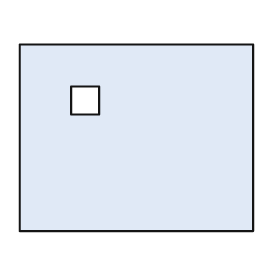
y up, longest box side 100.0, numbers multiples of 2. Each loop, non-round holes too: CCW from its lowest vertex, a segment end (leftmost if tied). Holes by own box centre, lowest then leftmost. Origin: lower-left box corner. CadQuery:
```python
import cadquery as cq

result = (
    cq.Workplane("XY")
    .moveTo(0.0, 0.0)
    .lineTo(100.0, 0.0)
    .lineTo(100.0, 80.0)
    .lineTo(0.0, 80.0)
    .close()
    .moveTo(22.0, 50.0)
    .lineTo(34.0, 50.0)
    .lineTo(34.0, 62.0)
    .lineTo(22.0, 62.0)
    .close()
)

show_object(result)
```